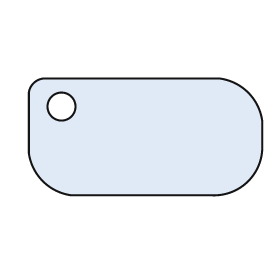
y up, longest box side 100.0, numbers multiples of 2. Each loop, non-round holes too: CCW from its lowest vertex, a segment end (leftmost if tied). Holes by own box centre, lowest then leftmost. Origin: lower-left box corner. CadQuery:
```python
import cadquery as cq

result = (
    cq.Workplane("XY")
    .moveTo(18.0, 0.0)
    .lineTo(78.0, 0.0)
    .threePointArc((94.0, 6.0), (100.0, 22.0))
    .lineTo(100.0, 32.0)
    .threePointArc((94.0, 44.0), (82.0, 50.0))
    .lineTo(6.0, 50.0)
    .threePointArc((2.0, 48.0), (0.0, 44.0))
    .lineTo(0.0, 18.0)
    .threePointArc((6.0, 6.0), (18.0, 0.0))
    .close()
    .moveTo(14.0, 38.0)
    .circle(6.0)
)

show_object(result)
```